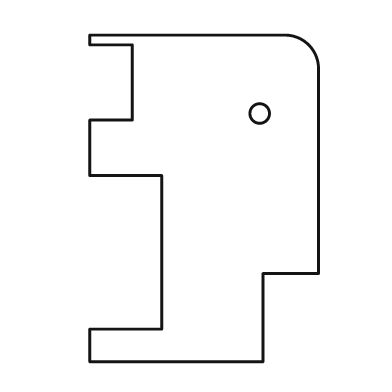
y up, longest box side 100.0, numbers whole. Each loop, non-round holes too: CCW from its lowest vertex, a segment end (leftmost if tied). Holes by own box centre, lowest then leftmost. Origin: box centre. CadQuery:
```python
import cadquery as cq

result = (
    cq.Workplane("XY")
    .moveTo(-35.0, -50.0)
    .lineTo(18.0, -50.0)
    .lineTo(18.0, -23.0)
    .lineTo(35.0, -23.0)
    .lineTo(35.0, 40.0)
    .threePointArc((32.0, 47.0), (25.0, 50.0))
    .lineTo(-35.0, 50.0)
    .lineTo(-35.0, 47.0)
    .lineTo(-22.0, 47.0)
    .lineTo(-22.0, 24.0)
    .lineTo(-35.0, 24.0)
    .lineTo(-35.0, 7.0)
    .lineTo(-13.0, 7.0)
    .lineTo(-13.0, -40.0)
    .lineTo(-35.0, -40.0)
    .close()
    .moveTo(17.0, 26.0)
    .circle(3.0)
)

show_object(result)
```